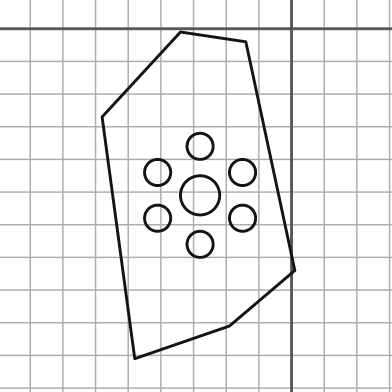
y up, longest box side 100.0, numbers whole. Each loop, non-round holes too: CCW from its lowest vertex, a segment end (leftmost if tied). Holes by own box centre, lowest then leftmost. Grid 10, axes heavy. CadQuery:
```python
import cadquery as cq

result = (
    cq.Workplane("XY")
    .moveTo(-48.0, -101.0)
    .lineTo(-19.0, -91.0)
    .lineTo(1.0, -74.0)
    .lineTo(-14.0, -4.0)
    .lineTo(-34.0, -1.0)
    .lineTo(-58.0, -27.0)
    .close()
    .moveTo(-28.0, -66.0)
    .circle(4.0)
    .moveTo(-41.0, -58.0)
    .circle(4.0)
    .moveTo(-15.0, -58.0)
    .circle(4.0)
    .moveTo(-28.0, -51.0)
    .circle(6.0)
    .moveTo(-41.0, -44.0)
    .circle(4.0)
    .moveTo(-15.0, -44.0)
    .circle(4.0)
    .moveTo(-28.0, -36.0)
    .circle(4.0)
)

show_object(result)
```